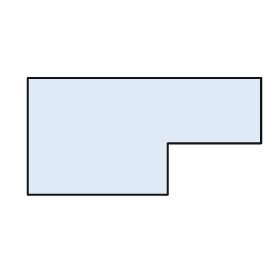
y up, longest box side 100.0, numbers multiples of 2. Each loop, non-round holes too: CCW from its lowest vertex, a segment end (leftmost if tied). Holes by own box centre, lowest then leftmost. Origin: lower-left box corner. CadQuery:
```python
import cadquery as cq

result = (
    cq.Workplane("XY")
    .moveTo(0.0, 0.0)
    .lineTo(60.0, 0.0)
    .lineTo(60.0, 22.0)
    .lineTo(100.0, 22.0)
    .lineTo(100.0, 50.0)
    .lineTo(0.0, 50.0)
    .close()
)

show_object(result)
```